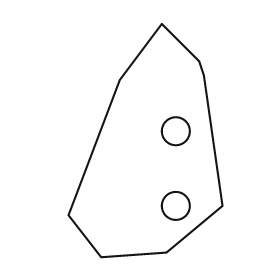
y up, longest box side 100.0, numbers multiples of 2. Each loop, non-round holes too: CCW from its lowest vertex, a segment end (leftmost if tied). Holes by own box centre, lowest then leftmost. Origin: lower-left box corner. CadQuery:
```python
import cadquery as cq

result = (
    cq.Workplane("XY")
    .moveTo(14.0, 0.0)
    .lineTo(42.0, 2.0)
    .lineTo(66.0, 22.0)
    .lineTo(58.0, 78.0)
    .lineTo(56.0, 84.0)
    .lineTo(40.0, 100.0)
    .lineTo(22.0, 76.0)
    .lineTo(0.0, 18.0)
    .close()
    .moveTo(46.0, 22.0)
    .circle(6.0)
    .moveTo(46.0, 54.0)
    .circle(6.0)
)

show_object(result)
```